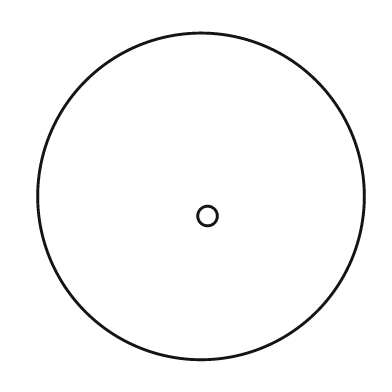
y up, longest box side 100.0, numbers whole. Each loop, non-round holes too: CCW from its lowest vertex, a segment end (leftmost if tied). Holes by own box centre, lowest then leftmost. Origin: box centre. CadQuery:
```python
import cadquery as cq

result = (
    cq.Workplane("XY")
    .moveTo(0.0, 0.0)
    .circle(50.0)
    .moveTo(2.0, -6.0)
    .circle(3.0)
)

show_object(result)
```